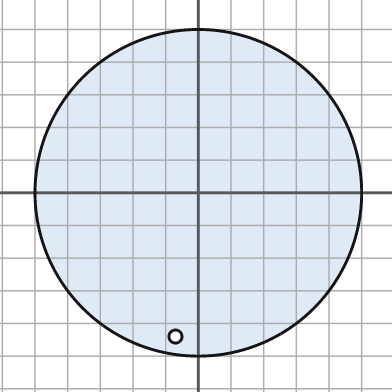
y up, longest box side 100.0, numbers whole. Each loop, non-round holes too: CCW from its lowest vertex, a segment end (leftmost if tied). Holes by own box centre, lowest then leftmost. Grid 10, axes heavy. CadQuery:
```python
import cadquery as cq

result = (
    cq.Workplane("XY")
    .moveTo(0.0, 0.0)
    .circle(50.0)
    .moveTo(-7.0, -44.0)
    .circle(2.0)
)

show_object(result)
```